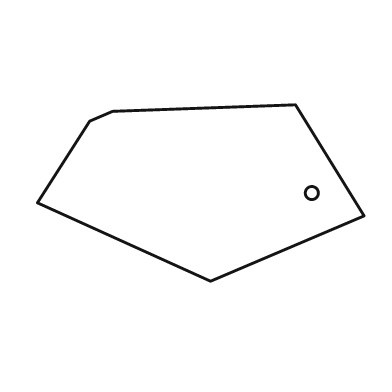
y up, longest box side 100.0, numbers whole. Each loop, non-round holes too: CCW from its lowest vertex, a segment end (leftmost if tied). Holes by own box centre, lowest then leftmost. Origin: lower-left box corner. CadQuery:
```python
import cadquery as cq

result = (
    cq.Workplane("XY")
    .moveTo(53.0, 0.0)
    .lineTo(100.0, 20.0)
    .lineTo(79.0, 54.0)
    .lineTo(23.0, 52.0)
    .lineTo(16.0, 49.0)
    .lineTo(0.0, 24.0)
    .close()
    .moveTo(84.0, 27.0)
    .circle(2.0)
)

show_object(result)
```